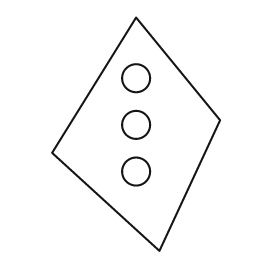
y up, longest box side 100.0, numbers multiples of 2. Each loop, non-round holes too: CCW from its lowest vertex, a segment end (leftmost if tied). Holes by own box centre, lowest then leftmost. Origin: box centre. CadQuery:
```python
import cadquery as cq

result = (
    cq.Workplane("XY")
    .moveTo(10.0, -50.0)
    .lineTo(36.0, 6.0)
    .lineTo(0.0, 50.0)
    .lineTo(-36.0, -8.0)
    .close()
    .moveTo(0.0, -16.0)
    .circle(6.0)
    .moveTo(0.0, 4.0)
    .circle(6.0)
    .moveTo(0.0, 24.0)
    .circle(6.0)
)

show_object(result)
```